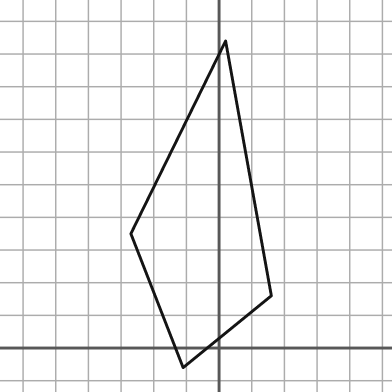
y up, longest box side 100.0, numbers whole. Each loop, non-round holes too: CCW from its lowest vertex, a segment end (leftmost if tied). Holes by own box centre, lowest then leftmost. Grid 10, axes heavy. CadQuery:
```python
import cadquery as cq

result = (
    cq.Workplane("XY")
    .moveTo(-11.0, -6.0)
    .lineTo(16.0, 16.0)
    .lineTo(2.0, 94.0)
    .lineTo(-27.0, 35.0)
    .close()
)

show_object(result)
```